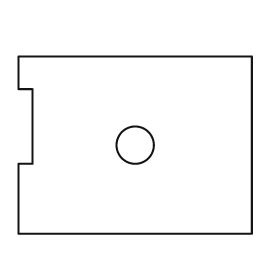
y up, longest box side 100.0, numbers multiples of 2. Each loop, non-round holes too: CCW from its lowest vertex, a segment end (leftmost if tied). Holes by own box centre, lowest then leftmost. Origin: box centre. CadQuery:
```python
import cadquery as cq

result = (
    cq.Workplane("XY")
    .moveTo(-50.0, -38.0)
    .lineTo(50.0, -38.0)
    .lineTo(50.0, 38.0)
    .lineTo(-50.0, 38.0)
    .lineTo(-50.0, 24.0)
    .lineTo(-44.0, 24.0)
    .lineTo(-44.0, -8.0)
    .lineTo(-50.0, -8.0)
    .close()
    .moveTo(0.0, 0.0)
    .circle(8.0)
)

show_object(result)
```